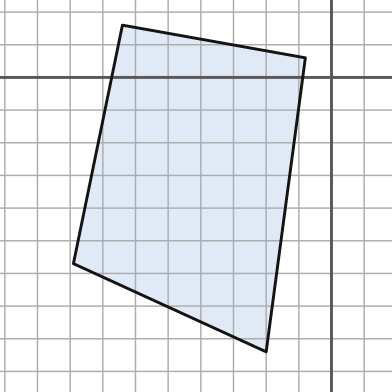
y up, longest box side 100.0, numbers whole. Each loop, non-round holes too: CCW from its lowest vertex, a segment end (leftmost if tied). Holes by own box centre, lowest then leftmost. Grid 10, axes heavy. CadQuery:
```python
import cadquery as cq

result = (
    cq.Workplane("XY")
    .moveTo(-20.0, -84.0)
    .lineTo(-8.0, 6.0)
    .lineTo(-64.0, 16.0)
    .lineTo(-79.0, -57.0)
    .close()
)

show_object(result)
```